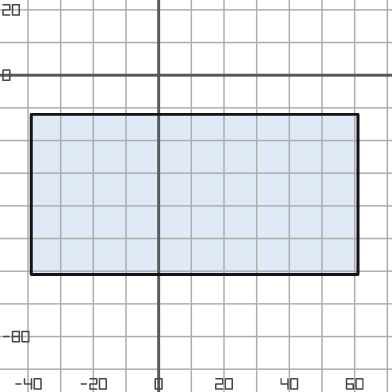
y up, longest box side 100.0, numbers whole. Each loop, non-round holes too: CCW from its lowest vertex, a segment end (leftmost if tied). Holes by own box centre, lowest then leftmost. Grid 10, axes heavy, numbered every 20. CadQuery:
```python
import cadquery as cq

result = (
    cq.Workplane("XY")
    .moveTo(-39.0, -61.0)
    .lineTo(61.0, -61.0)
    .lineTo(61.0, -12.0)
    .lineTo(-39.0, -12.0)
    .close()
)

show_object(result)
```